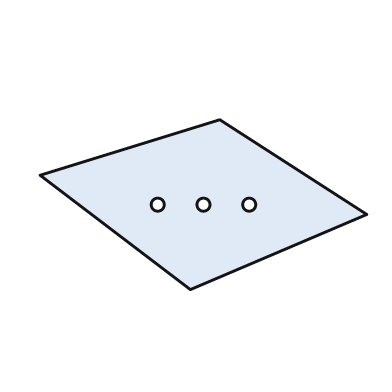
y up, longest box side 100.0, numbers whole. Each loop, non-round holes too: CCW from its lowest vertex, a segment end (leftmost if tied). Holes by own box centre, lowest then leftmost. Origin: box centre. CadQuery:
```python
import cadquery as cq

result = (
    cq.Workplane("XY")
    .moveTo(-4.0, -26.0)
    .lineTo(50.0, -3.0)
    .lineTo(5.0, 26.0)
    .lineTo(-50.0, 9.0)
    .close()
    .moveTo(-14.0, 0.0)
    .circle(2.0)
    .moveTo(0.0, 0.0)
    .circle(2.0)
    .moveTo(14.0, 0.0)
    .circle(2.0)
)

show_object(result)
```